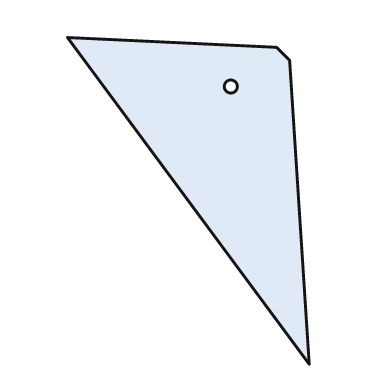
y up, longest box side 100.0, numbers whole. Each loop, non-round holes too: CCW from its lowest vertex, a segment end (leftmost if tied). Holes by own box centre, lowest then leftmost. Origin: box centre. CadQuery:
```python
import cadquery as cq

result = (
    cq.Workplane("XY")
    .moveTo(37.0, -50.0)
    .lineTo(31.0, 43.0)
    .lineTo(27.0, 47.0)
    .lineTo(-37.0, 50.0)
    .close()
    .moveTo(13.0, 35.0)
    .circle(2.0)
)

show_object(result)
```